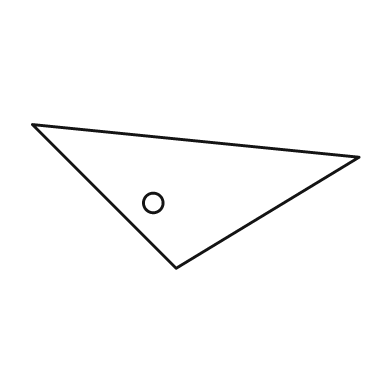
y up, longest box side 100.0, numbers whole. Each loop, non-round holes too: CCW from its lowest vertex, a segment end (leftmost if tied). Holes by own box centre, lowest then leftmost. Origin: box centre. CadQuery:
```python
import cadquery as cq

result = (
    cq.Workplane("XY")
    .moveTo(-6.0, -22.0)
    .lineTo(50.0, 12.0)
    .lineTo(-50.0, 22.0)
    .close()
    .moveTo(-13.0, -2.0)
    .circle(3.0)
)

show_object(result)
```